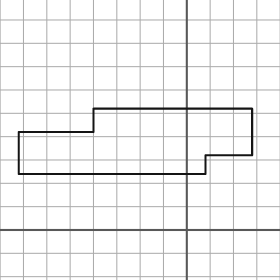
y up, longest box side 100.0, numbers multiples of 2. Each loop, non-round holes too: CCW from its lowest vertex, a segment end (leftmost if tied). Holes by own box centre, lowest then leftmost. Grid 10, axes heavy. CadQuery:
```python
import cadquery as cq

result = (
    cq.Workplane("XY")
    .moveTo(-72.0, 24.0)
    .lineTo(8.0, 24.0)
    .lineTo(8.0, 32.0)
    .lineTo(28.0, 32.0)
    .lineTo(28.0, 52.0)
    .lineTo(-40.0, 52.0)
    .lineTo(-40.0, 42.0)
    .lineTo(-72.0, 42.0)
    .close()
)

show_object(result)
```